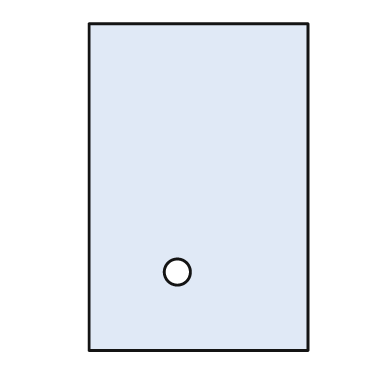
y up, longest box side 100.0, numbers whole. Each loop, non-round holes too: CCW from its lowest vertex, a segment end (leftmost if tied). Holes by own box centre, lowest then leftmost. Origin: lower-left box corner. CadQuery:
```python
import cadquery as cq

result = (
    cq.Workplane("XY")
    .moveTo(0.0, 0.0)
    .lineTo(67.0, 0.0)
    .lineTo(67.0, 100.0)
    .lineTo(0.0, 100.0)
    .close()
    .moveTo(27.0, 24.0)
    .circle(4.0)
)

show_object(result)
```